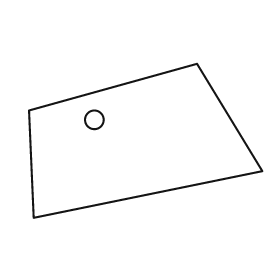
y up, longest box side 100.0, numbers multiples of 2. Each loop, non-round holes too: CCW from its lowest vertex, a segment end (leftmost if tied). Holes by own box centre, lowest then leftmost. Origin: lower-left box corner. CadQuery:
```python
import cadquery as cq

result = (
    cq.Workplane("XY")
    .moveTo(2.0, 0.0)
    .lineTo(100.0, 20.0)
    .lineTo(72.0, 66.0)
    .lineTo(0.0, 46.0)
    .close()
    .moveTo(28.0, 42.0)
    .circle(4.0)
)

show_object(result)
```